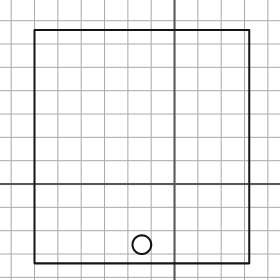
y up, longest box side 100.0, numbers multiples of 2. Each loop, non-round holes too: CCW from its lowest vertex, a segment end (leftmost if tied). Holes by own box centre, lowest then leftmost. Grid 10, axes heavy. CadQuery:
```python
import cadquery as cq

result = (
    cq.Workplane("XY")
    .moveTo(-60.0, -34.0)
    .lineTo(32.0, -34.0)
    .lineTo(32.0, 66.0)
    .lineTo(-60.0, 66.0)
    .close()
    .moveTo(-14.0, -26.0)
    .circle(4.0)
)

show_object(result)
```